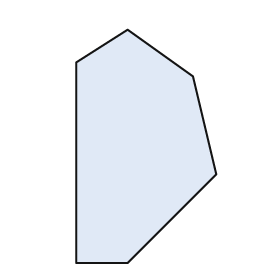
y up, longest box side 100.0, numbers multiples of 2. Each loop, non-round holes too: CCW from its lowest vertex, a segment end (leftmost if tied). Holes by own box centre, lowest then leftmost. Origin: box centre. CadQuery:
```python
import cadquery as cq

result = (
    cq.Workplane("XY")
    .moveTo(-30.0, -50.0)
    .lineTo(-8.0, -50.0)
    .lineTo(30.0, -12.0)
    .lineTo(20.0, 30.0)
    .lineTo(-8.0, 50.0)
    .lineTo(-30.0, 36.0)
    .close()
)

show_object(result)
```